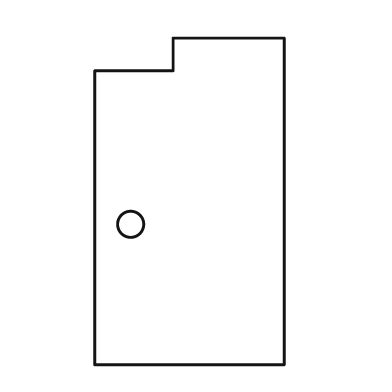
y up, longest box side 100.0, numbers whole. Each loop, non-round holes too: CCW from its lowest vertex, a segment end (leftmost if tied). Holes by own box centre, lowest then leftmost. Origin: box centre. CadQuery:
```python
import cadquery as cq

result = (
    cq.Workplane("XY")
    .moveTo(-29.0, -50.0)
    .lineTo(29.0, -50.0)
    .lineTo(29.0, 50.0)
    .lineTo(-5.0, 50.0)
    .lineTo(-5.0, 40.0)
    .lineTo(-29.0, 40.0)
    .close()
    .moveTo(-18.0, -7.0)
    .circle(4.0)
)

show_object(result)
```